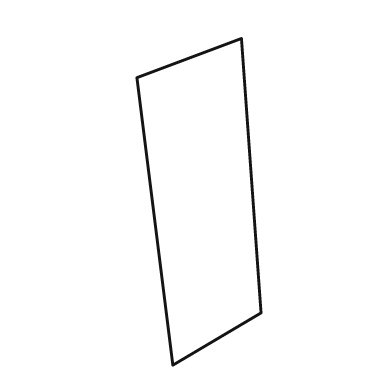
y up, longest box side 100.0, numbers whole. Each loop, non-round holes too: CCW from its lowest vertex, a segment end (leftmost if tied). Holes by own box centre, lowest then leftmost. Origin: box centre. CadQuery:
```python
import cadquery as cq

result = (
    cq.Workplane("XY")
    .moveTo(-8.0, -50.0)
    .lineTo(19.0, -34.0)
    .lineTo(13.0, 50.0)
    .lineTo(-19.0, 38.0)
    .close()
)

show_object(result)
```